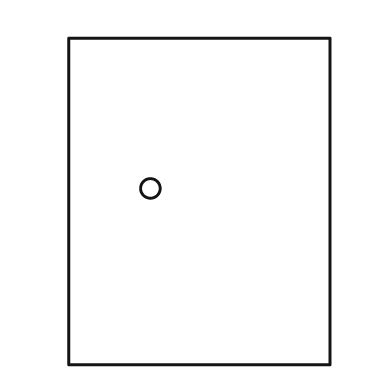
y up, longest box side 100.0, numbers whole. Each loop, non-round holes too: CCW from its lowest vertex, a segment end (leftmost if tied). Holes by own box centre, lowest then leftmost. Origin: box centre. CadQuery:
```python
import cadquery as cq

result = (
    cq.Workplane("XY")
    .moveTo(-40.0, -50.0)
    .lineTo(40.0, -50.0)
    .lineTo(40.0, 50.0)
    .lineTo(-40.0, 50.0)
    .close()
    .moveTo(-15.0, 4.0)
    .circle(3.0)
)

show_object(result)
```